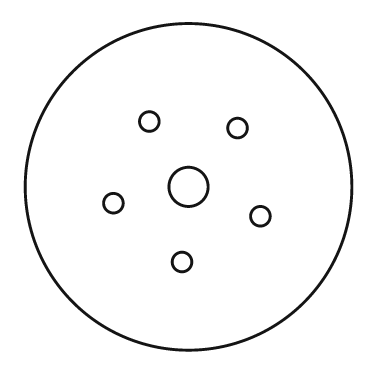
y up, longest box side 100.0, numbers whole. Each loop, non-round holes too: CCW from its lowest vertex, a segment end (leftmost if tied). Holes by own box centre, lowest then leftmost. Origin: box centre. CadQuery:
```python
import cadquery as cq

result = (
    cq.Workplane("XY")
    .moveTo(0.0, 0.0)
    .circle(50.0)
    .moveTo(-2.0, -23.0)
    .circle(3.0)
    .moveTo(22.0, -9.0)
    .circle(3.0)
    .moveTo(-23.0, -5.0)
    .circle(3.0)
    .moveTo(0.0, 0.0)
    .circle(6.0)
    .moveTo(15.0, 18.0)
    .circle(3.0)
    .moveTo(-12.0, 20.0)
    .circle(3.0)
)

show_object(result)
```